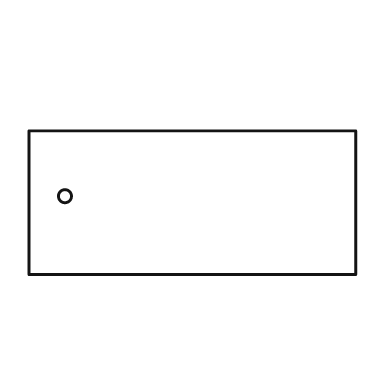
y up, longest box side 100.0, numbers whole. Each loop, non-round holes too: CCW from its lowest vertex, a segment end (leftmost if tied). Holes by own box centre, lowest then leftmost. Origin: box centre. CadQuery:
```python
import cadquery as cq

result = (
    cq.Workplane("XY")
    .moveTo(-50.0, -22.0)
    .lineTo(50.0, -22.0)
    .lineTo(50.0, 22.0)
    .lineTo(-50.0, 22.0)
    .close()
    .moveTo(-39.0, 2.0)
    .circle(2.0)
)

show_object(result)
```